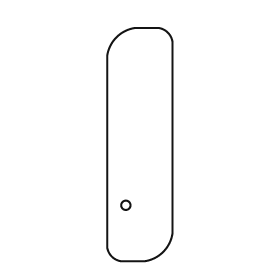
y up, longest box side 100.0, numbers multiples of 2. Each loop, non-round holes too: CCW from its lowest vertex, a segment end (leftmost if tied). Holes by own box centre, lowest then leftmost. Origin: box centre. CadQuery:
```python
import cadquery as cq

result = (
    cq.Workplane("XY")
    .moveTo(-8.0, -50.0)
    .lineTo(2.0, -50.0)
    .threePointArc((10.0, -46.0), (14.0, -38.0))
    .lineTo(14.0, 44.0)
    .threePointArc((12.0, 48.0), (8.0, 50.0))
    .lineTo(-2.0, 50.0)
    .threePointArc((-10.0, 46.0), (-14.0, 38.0))
    .lineTo(-14.0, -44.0)
    .threePointArc((-12.0, -48.0), (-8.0, -50.0))
    .close()
    .moveTo(-6.0, -26.0)
    .circle(2.0)
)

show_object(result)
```